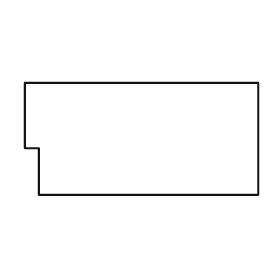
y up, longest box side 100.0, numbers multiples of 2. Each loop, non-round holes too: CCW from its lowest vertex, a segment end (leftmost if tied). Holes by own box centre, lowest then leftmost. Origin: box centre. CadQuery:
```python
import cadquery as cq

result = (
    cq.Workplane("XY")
    .moveTo(-44.0, -24.0)
    .lineTo(50.0, -24.0)
    .lineTo(50.0, 24.0)
    .lineTo(-50.0, 24.0)
    .lineTo(-50.0, -4.0)
    .lineTo(-44.0, -4.0)
    .close()
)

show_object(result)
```